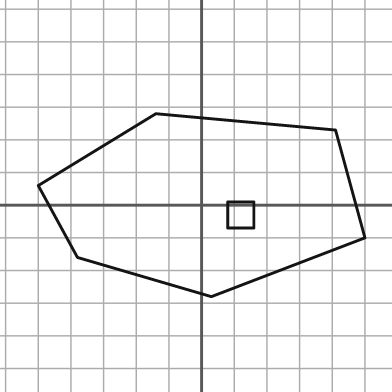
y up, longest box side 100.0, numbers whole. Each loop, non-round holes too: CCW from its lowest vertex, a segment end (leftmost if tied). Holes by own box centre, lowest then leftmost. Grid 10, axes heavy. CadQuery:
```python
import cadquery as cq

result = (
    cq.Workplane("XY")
    .moveTo(3.0, -28.0)
    .lineTo(50.0, -10.0)
    .lineTo(41.0, 23.0)
    .lineTo(-14.0, 28.0)
    .lineTo(-50.0, 6.0)
    .lineTo(-38.0, -16.0)
    .close()
    .moveTo(8.0, -7.0)
    .lineTo(16.0, -7.0)
    .lineTo(16.0, 1.0)
    .lineTo(8.0, 1.0)
    .close()
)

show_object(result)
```